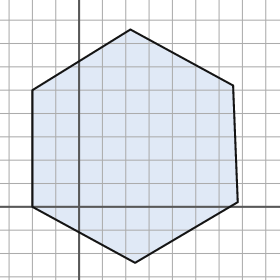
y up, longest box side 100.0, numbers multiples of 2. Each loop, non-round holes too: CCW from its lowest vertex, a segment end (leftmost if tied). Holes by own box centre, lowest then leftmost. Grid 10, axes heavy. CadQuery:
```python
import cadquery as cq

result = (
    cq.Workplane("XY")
    .moveTo(24.0, -24.0)
    .lineTo(68.0, 2.0)
    .lineTo(66.0, 52.0)
    .lineTo(22.0, 76.0)
    .lineTo(-20.0, 50.0)
    .lineTo(-20.0, 0.0)
    .close()
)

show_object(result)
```